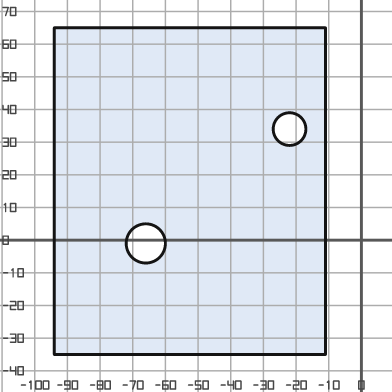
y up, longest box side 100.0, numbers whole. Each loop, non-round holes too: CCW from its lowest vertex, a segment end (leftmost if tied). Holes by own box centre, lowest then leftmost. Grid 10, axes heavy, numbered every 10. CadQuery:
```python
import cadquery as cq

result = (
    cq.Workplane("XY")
    .moveTo(-94.0, -35.0)
    .lineTo(-11.0, -35.0)
    .lineTo(-11.0, 65.0)
    .lineTo(-94.0, 65.0)
    .close()
    .moveTo(-66.0, -1.0)
    .circle(6.0)
    .moveTo(-22.0, 34.0)
    .circle(5.0)
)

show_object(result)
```